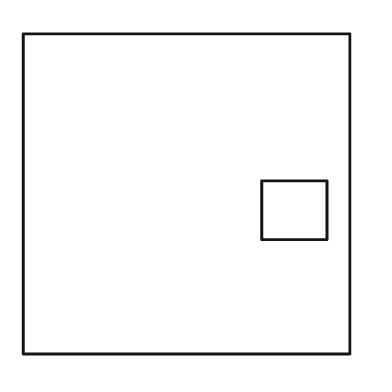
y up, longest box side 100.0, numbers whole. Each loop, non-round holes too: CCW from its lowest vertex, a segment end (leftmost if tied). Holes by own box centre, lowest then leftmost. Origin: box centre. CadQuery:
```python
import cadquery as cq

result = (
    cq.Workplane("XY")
    .moveTo(-50.0, -49.0)
    .lineTo(50.0, -49.0)
    .lineTo(50.0, 49.0)
    .lineTo(-50.0, 49.0)
    .close()
    .moveTo(23.0, -14.0)
    .lineTo(43.0, -14.0)
    .lineTo(43.0, 4.0)
    .lineTo(23.0, 4.0)
    .close()
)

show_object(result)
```